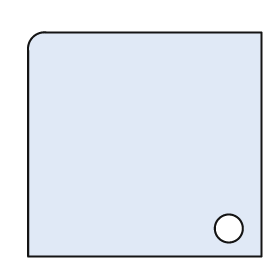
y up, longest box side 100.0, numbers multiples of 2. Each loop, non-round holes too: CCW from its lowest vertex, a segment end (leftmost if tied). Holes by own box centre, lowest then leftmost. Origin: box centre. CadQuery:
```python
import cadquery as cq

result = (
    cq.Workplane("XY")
    .moveTo(-50.0, -48.0)
    .lineTo(50.0, -48.0)
    .lineTo(50.0, 48.0)
    .lineTo(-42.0, 48.0)
    .threePointArc((-48.0, 46.0), (-50.0, 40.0))
    .close()
    .moveTo(36.0, -36.0)
    .circle(6.0)
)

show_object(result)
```